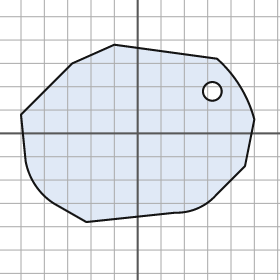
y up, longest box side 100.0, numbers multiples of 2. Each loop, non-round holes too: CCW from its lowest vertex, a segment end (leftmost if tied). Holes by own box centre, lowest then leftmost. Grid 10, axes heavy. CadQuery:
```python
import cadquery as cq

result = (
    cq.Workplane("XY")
    .moveTo(-22.0, -38.0)
    .lineTo(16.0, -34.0)
    .threePointArc((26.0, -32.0), (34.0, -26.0))
    .lineTo(46.0, -14.0)
    .lineTo(50.0, 6.0)
    .threePointArc((44.0, 20.0), (34.0, 32.0))
    .lineTo(-10.0, 38.0)
    .lineTo(-28.0, 30.0)
    .lineTo(-50.0, 8.0)
    .lineTo(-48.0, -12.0)
    .threePointArc((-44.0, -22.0), (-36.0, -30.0))
    .close()
    .moveTo(32.0, 18.0)
    .circle(4.0)
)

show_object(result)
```